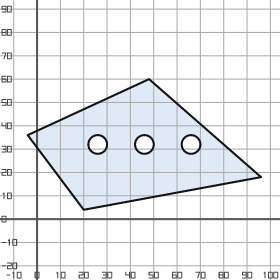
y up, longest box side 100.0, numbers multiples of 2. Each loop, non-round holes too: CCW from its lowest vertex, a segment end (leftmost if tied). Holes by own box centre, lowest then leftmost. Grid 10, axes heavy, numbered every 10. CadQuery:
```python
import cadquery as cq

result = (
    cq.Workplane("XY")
    .moveTo(20.0, 4.0)
    .lineTo(96.0, 18.0)
    .lineTo(48.0, 60.0)
    .lineTo(-4.0, 36.0)
    .close()
    .moveTo(26.0, 32.0)
    .circle(4.0)
    .moveTo(46.0, 32.0)
    .circle(4.0)
    .moveTo(66.0, 32.0)
    .circle(4.0)
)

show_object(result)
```